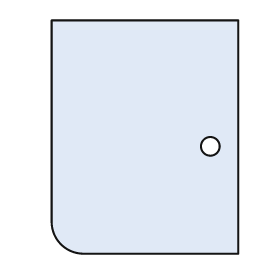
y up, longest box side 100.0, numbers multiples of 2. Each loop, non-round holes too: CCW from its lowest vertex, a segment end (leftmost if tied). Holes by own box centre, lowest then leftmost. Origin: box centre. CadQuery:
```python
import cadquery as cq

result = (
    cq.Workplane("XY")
    .moveTo(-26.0, -50.0)
    .lineTo(40.0, -50.0)
    .lineTo(40.0, 50.0)
    .lineTo(-40.0, 50.0)
    .lineTo(-40.0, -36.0)
    .threePointArc((-36.0, -46.0), (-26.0, -50.0))
    .close()
    .moveTo(28.0, -4.0)
    .circle(4.0)
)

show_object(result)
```